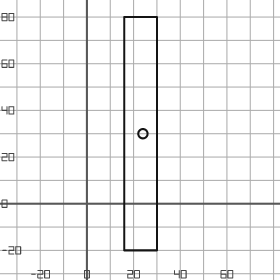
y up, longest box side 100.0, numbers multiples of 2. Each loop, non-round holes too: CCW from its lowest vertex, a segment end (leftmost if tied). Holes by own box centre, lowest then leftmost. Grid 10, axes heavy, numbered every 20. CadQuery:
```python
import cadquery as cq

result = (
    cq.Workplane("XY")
    .moveTo(16.0, -20.0)
    .lineTo(30.0, -20.0)
    .lineTo(30.0, 80.0)
    .lineTo(16.0, 80.0)
    .close()
    .moveTo(24.0, 30.0)
    .circle(2.0)
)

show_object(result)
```